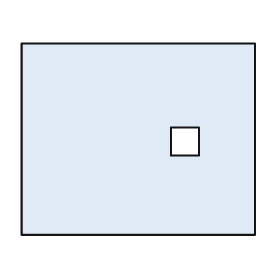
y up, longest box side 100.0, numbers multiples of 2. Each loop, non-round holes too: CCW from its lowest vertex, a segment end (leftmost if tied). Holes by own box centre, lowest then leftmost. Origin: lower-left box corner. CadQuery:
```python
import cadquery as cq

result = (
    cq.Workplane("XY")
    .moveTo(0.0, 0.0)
    .lineTo(100.0, 0.0)
    .lineTo(100.0, 82.0)
    .lineTo(0.0, 82.0)
    .close()
    .moveTo(64.0, 34.0)
    .lineTo(76.0, 34.0)
    .lineTo(76.0, 46.0)
    .lineTo(64.0, 46.0)
    .close()
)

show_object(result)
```